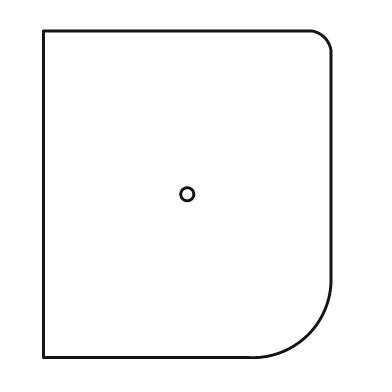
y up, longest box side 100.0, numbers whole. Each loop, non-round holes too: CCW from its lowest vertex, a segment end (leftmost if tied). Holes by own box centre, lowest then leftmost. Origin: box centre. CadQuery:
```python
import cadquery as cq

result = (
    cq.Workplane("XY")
    .moveTo(-44.0, -50.0)
    .lineTo(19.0, -50.0)
    .threePointArc((37.0, -43.0), (44.0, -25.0))
    .lineTo(44.0, 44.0)
    .threePointArc((42.0, 48.0), (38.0, 50.0))
    .lineTo(-44.0, 50.0)
    .close()
    .moveTo(0.0, 0.0)
    .circle(2.0)
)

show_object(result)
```